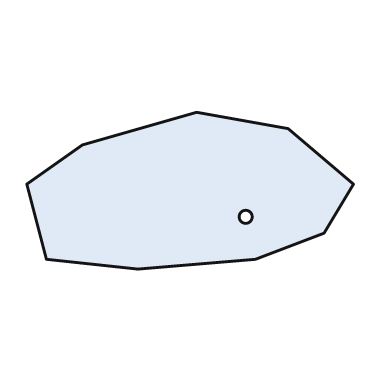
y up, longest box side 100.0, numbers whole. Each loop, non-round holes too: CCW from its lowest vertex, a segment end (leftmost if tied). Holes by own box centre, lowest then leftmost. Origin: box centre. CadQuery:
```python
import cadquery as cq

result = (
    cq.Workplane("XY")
    .moveTo(-16.0, -24.0)
    .lineTo(20.0, -21.0)
    .lineTo(41.0, -13.0)
    .lineTo(50.0, 2.0)
    .lineTo(30.0, 19.0)
    .lineTo(2.0, 24.0)
    .lineTo(-33.0, 14.0)
    .lineTo(-50.0, 2.0)
    .lineTo(-44.0, -21.0)
    .close()
    .moveTo(17.0, -8.0)
    .circle(2.0)
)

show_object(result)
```